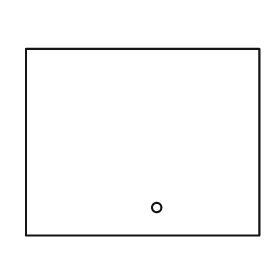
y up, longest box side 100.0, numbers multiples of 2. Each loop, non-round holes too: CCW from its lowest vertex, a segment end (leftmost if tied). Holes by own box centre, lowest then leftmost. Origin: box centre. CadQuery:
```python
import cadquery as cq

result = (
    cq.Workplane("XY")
    .moveTo(-50.0, -40.0)
    .lineTo(50.0, -40.0)
    .lineTo(50.0, 40.0)
    .lineTo(-50.0, 40.0)
    .close()
    .moveTo(6.0, -28.0)
    .circle(2.0)
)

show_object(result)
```